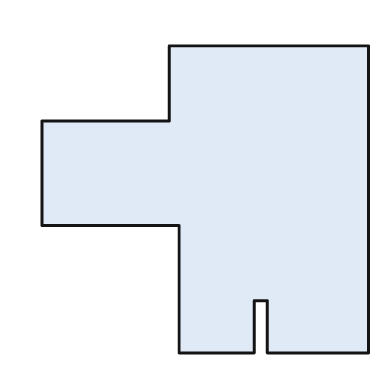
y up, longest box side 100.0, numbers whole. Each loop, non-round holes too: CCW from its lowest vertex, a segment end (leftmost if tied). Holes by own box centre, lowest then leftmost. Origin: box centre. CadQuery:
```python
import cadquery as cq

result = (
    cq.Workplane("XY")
    .moveTo(-8.0, -47.0)
    .lineTo(15.0, -47.0)
    .lineTo(15.0, -31.0)
    .lineTo(19.0, -31.0)
    .lineTo(19.0, -47.0)
    .lineTo(50.0, -47.0)
    .lineTo(50.0, 47.0)
    .lineTo(-11.0, 47.0)
    .lineTo(-11.0, 24.0)
    .lineTo(-50.0, 24.0)
    .lineTo(-50.0, -8.0)
    .lineTo(-8.0, -8.0)
    .close()
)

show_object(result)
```